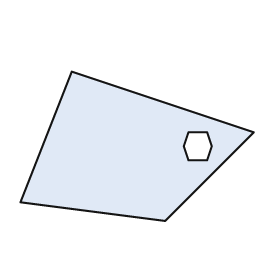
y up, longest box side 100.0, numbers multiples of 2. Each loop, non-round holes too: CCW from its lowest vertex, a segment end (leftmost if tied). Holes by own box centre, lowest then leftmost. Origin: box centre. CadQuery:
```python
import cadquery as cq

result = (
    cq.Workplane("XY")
    .moveTo(12.0, -32.0)
    .lineTo(50.0, 6.0)
    .lineTo(-28.0, 32.0)
    .lineTo(-50.0, -24.0)
    .close()
    .moveTo(22.0, -6.0)
    .lineTo(30.0, -6.0)
    .lineTo(32.0, 0.0)
    .lineTo(30.0, 6.0)
    .lineTo(22.0, 6.0)
    .lineTo(20.0, 0.0)
    .close()
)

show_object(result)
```